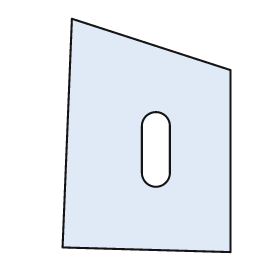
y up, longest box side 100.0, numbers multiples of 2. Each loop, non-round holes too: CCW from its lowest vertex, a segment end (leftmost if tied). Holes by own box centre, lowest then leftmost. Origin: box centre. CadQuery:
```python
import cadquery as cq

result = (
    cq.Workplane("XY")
    .moveTo(36.0, -50.0)
    .lineTo(36.0, 28.0)
    .lineTo(-32.0, 50.0)
    .lineTo(-36.0, -48.0)
    .close()
    .moveTo(-2.0, -16.0)
    .threePointArc((4.0, -22.0), (10.0, -16.0))
    .lineTo(10.0, 4.0)
    .threePointArc((4.0, 10.0), (-2.0, 4.0))
    .close()
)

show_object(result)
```